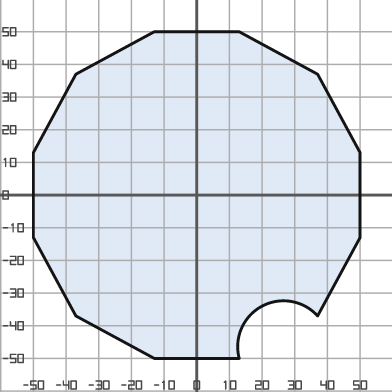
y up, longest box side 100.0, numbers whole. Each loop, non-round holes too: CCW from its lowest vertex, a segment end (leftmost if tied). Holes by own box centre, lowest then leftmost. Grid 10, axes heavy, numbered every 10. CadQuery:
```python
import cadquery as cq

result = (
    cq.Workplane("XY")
    .moveTo(-13.0, -50.0)
    .lineTo(13.0, -50.0)
    .threePointArc((20.0, -34.0), (37.0, -37.0))
    .lineTo(50.0, -13.0)
    .lineTo(50.0, 13.0)
    .lineTo(37.0, 37.0)
    .lineTo(13.0, 50.0)
    .lineTo(-13.0, 50.0)
    .lineTo(-37.0, 37.0)
    .lineTo(-50.0, 13.0)
    .lineTo(-50.0, -13.0)
    .lineTo(-37.0, -37.0)
    .close()
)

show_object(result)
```